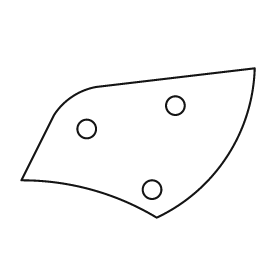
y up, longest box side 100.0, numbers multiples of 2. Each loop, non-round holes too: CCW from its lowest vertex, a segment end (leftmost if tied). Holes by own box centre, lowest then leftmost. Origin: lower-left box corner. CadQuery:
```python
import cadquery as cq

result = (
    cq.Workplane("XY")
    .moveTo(58.0, 0.0)
    .threePointArc((88.0, 26.0), (100.0, 64.0))
    .lineTo(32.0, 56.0)
    .threePointArc((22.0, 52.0), (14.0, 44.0))
    .lineTo(0.0, 16.0)
    .threePointArc((30.0, 12.0), (58.0, 0.0))
    .close()
    .moveTo(56.0, 12.0)
    .circle(4.0)
    .moveTo(28.0, 38.0)
    .circle(4.0)
    .moveTo(66.0, 48.0)
    .circle(4.0)
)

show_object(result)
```